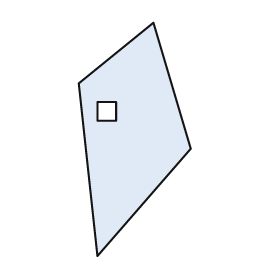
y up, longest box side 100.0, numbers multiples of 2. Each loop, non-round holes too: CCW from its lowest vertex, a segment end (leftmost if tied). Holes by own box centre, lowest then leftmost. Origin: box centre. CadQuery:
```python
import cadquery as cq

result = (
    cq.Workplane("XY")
    .moveTo(-16.0, -50.0)
    .lineTo(24.0, -4.0)
    .lineTo(8.0, 50.0)
    .lineTo(-24.0, 24.0)
    .close()
    .moveTo(-16.0, 8.0)
    .lineTo(-8.0, 8.0)
    .lineTo(-8.0, 16.0)
    .lineTo(-16.0, 16.0)
    .close()
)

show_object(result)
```